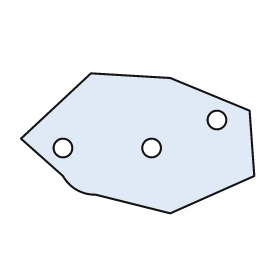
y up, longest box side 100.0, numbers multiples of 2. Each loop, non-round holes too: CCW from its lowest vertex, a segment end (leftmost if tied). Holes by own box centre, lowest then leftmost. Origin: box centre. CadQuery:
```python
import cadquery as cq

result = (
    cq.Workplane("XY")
    .moveTo(14.0, -30.0)
    .lineTo(50.0, -14.0)
    .lineTo(48.0, 14.0)
    .lineTo(14.0, 28.0)
    .lineTo(-20.0, 30.0)
    .lineTo(-50.0, 2.0)
    .lineTo(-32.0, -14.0)
    .threePointArc((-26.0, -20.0), (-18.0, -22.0))
    .close()
    .moveTo(-32.0, -2.0)
    .circle(4.0)
    .moveTo(6.0, -2.0)
    .circle(4.0)
    .moveTo(34.0, 10.0)
    .circle(4.0)
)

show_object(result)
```